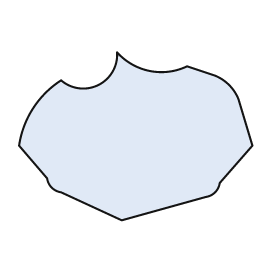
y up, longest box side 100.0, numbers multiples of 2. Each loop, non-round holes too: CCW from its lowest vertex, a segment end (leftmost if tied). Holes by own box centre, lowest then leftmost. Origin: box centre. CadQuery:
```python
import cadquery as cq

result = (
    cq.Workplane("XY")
    .moveTo(-6.0, -36.0)
    .lineTo(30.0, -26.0)
    .threePointArc((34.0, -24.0), (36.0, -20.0))
    .lineTo(50.0, -4.0)
    .lineTo(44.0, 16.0)
    .threePointArc((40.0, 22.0), (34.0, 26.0))
    .lineTo(22.0, 30.0)
    .threePointArc((6.0, 28.0), (-8.0, 36.0))
    .threePointArc((-16.0, 22.0), (-32.0, 24.0))
    .threePointArc((-44.0, 12.0), (-50.0, -4.0))
    .lineTo(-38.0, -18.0)
    .threePointArc((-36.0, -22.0), (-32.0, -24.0))
    .close()
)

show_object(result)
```